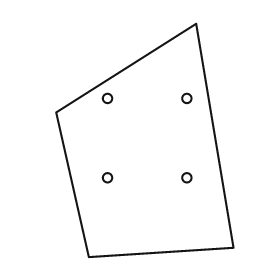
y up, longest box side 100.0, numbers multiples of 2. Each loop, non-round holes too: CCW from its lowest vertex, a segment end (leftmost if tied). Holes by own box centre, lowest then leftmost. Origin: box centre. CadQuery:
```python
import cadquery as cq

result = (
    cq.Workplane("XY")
    .moveTo(-24.0, -50.0)
    .lineTo(38.0, -46.0)
    .lineTo(22.0, 50.0)
    .lineTo(-38.0, 12.0)
    .close()
    .moveTo(-16.0, -16.0)
    .circle(2.0)
    .moveTo(18.0, -16.0)
    .circle(2.0)
    .moveTo(-16.0, 18.0)
    .circle(2.0)
    .moveTo(18.0, 18.0)
    .circle(2.0)
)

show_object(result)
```